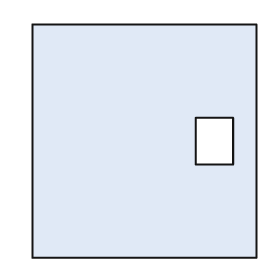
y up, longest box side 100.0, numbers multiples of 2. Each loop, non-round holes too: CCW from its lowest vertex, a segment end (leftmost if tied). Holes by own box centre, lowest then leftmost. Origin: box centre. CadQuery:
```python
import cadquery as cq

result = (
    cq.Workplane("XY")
    .moveTo(-48.0, -50.0)
    .lineTo(48.0, -50.0)
    .lineTo(48.0, 50.0)
    .lineTo(-48.0, 50.0)
    .close()
    .moveTo(22.0, -10.0)
    .lineTo(38.0, -10.0)
    .lineTo(38.0, 10.0)
    .lineTo(22.0, 10.0)
    .close()
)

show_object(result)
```